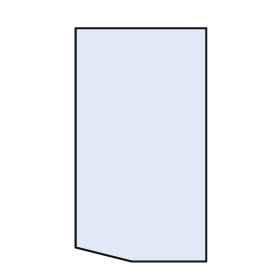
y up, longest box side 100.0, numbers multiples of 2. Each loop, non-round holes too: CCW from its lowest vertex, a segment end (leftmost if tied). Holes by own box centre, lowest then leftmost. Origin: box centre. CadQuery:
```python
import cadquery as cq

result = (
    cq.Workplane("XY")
    .moveTo(-4.0, -50.0)
    .lineTo(28.0, -50.0)
    .lineTo(28.0, 50.0)
    .lineTo(-28.0, 50.0)
    .lineTo(-28.0, -44.0)
    .close()
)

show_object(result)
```